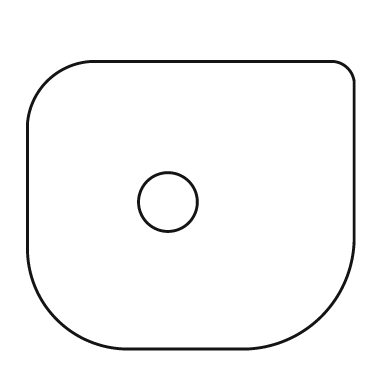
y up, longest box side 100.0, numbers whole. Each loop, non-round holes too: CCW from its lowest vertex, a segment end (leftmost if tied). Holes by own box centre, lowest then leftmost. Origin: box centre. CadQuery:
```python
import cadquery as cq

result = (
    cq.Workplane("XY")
    .moveTo(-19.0, -44.0)
    .lineTo(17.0, -44.0)
    .threePointArc((40.0, -34.0), (50.0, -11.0))
    .lineTo(50.0, 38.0)
    .threePointArc((48.0, 42.0), (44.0, 44.0))
    .lineTo(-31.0, 44.0)
    .threePointArc((-44.0, 38.0), (-50.0, 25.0))
    .lineTo(-50.0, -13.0)
    .threePointArc((-41.0, -35.0), (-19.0, -44.0))
    .close()
    .moveTo(-7.0, 1.0)
    .circle(9.0)
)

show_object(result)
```